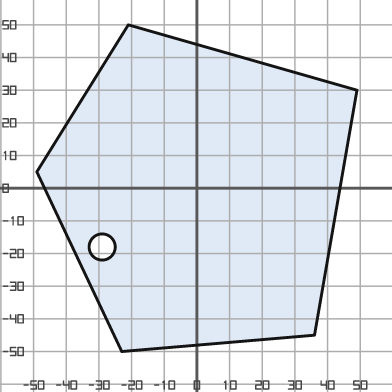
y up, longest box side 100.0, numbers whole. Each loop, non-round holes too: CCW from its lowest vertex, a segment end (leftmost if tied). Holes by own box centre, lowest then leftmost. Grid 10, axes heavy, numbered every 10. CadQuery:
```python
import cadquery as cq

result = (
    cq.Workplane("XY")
    .moveTo(-23.0, -50.0)
    .lineTo(36.0, -45.0)
    .lineTo(49.0, 30.0)
    .lineTo(-21.0, 50.0)
    .lineTo(-49.0, 5.0)
    .close()
    .moveTo(-29.0, -18.0)
    .circle(4.0)
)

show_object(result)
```